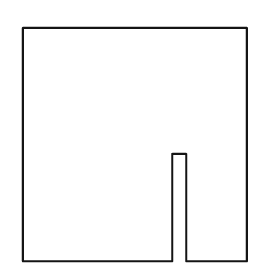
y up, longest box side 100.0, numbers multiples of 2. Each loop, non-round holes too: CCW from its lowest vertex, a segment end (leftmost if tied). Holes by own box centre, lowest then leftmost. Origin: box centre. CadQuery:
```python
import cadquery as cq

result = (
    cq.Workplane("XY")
    .moveTo(-48.0, -50.0)
    .lineTo(16.0, -50.0)
    .lineTo(16.0, -4.0)
    .lineTo(22.0, -4.0)
    .lineTo(22.0, -50.0)
    .lineTo(48.0, -50.0)
    .lineTo(48.0, 50.0)
    .lineTo(-48.0, 50.0)
    .close()
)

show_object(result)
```